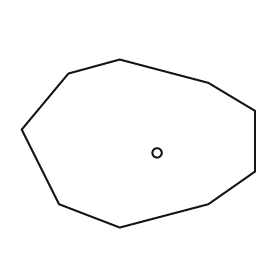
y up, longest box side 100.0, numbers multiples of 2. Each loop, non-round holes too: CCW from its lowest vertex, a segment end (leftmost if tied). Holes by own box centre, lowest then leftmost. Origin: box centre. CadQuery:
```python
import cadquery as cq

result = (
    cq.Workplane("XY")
    .moveTo(-8.0, -36.0)
    .lineTo(30.0, -26.0)
    .lineTo(50.0, -12.0)
    .lineTo(50.0, 14.0)
    .lineTo(30.0, 26.0)
    .lineTo(-8.0, 36.0)
    .lineTo(-30.0, 30.0)
    .lineTo(-50.0, 6.0)
    .lineTo(-34.0, -26.0)
    .close()
    .moveTo(8.0, -4.0)
    .circle(2.0)
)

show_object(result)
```